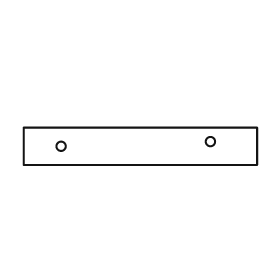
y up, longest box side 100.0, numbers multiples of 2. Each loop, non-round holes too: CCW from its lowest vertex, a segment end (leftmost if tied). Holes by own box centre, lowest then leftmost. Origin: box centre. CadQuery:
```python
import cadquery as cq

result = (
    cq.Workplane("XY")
    .moveTo(-50.0, -8.0)
    .lineTo(50.0, -8.0)
    .lineTo(50.0, 8.0)
    .lineTo(-50.0, 8.0)
    .close()
    .moveTo(-34.0, 0.0)
    .circle(2.0)
    .moveTo(30.0, 2.0)
    .circle(2.0)
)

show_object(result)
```